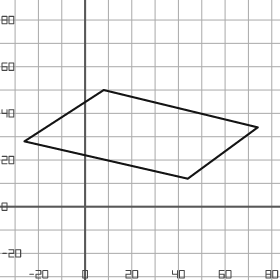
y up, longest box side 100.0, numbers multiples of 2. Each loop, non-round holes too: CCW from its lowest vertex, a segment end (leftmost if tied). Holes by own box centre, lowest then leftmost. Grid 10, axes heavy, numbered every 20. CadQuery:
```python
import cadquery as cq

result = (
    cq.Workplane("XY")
    .moveTo(44.0, 12.0)
    .lineTo(74.0, 34.0)
    .lineTo(8.0, 50.0)
    .lineTo(-26.0, 28.0)
    .close()
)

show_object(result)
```